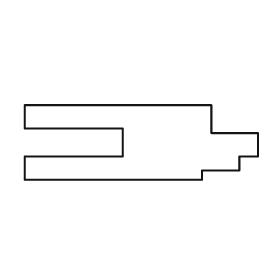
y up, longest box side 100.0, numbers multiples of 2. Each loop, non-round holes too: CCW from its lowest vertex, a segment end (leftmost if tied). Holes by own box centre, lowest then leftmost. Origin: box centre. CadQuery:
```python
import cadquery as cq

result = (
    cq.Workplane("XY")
    .moveTo(-50.0, -16.0)
    .lineTo(26.0, -16.0)
    .lineTo(26.0, -12.0)
    .lineTo(42.0, -12.0)
    .lineTo(42.0, -6.0)
    .lineTo(50.0, -6.0)
    .lineTo(50.0, 4.0)
    .lineTo(30.0, 4.0)
    .lineTo(30.0, 16.0)
    .lineTo(-50.0, 16.0)
    .lineTo(-50.0, 6.0)
    .lineTo(-8.0, 6.0)
    .lineTo(-8.0, -6.0)
    .lineTo(-50.0, -6.0)
    .close()
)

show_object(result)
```